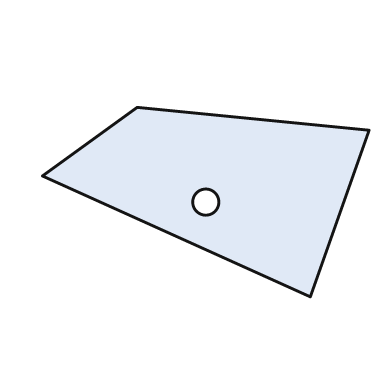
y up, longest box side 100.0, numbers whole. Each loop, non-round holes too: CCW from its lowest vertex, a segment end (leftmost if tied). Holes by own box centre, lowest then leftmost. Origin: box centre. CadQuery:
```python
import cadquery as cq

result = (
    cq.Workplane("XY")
    .moveTo(32.0, -29.0)
    .lineTo(50.0, 22.0)
    .lineTo(-21.0, 29.0)
    .lineTo(-50.0, 8.0)
    .close()
    .moveTo(0.0, 0.0)
    .circle(4.0)
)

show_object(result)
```